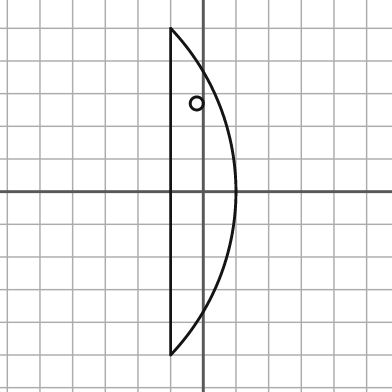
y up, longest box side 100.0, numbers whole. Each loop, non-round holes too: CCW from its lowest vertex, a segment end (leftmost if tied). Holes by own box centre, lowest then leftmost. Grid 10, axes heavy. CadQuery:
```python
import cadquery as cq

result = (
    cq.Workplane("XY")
    .moveTo(-10.0, -50.0)
    .threePointArc((10.0, 0.0), (-10.0, 50.0))
    .close()
    .moveTo(-2.0, 27.0)
    .circle(2.0)
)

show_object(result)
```